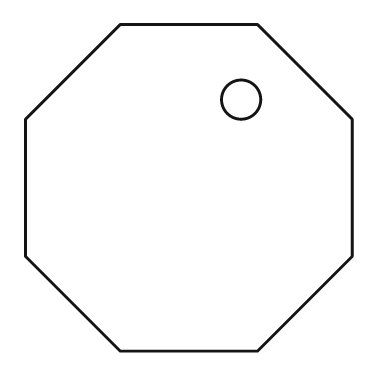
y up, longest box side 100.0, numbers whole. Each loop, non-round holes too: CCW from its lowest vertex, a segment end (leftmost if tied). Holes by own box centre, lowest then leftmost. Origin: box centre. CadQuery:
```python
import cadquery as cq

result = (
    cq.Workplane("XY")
    .moveTo(-21.0, -50.0)
    .lineTo(21.0, -50.0)
    .lineTo(50.0, -21.0)
    .lineTo(50.0, 21.0)
    .lineTo(21.0, 50.0)
    .lineTo(-21.0, 50.0)
    .lineTo(-50.0, 21.0)
    .lineTo(-50.0, -21.0)
    .close()
    .moveTo(16.0, 27.0)
    .circle(6.0)
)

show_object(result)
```